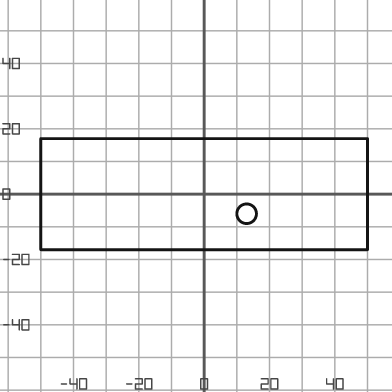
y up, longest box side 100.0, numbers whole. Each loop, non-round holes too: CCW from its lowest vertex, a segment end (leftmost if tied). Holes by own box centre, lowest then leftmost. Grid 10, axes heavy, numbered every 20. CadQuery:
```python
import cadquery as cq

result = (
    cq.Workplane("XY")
    .moveTo(-50.0, -17.0)
    .lineTo(50.0, -17.0)
    .lineTo(50.0, 17.0)
    .lineTo(-50.0, 17.0)
    .close()
    .moveTo(13.0, -6.0)
    .circle(3.0)
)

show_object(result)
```